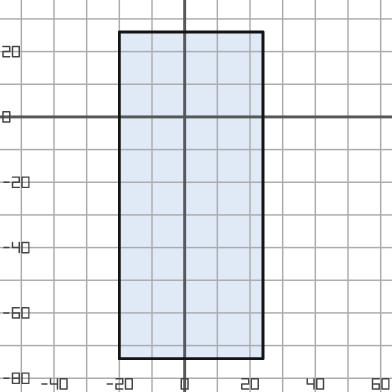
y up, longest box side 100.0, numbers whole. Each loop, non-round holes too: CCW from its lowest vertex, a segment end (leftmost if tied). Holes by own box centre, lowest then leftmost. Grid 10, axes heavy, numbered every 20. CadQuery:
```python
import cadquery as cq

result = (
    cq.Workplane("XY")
    .moveTo(-20.0, -74.0)
    .lineTo(24.0, -74.0)
    .lineTo(24.0, 26.0)
    .lineTo(-20.0, 26.0)
    .close()
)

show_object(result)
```